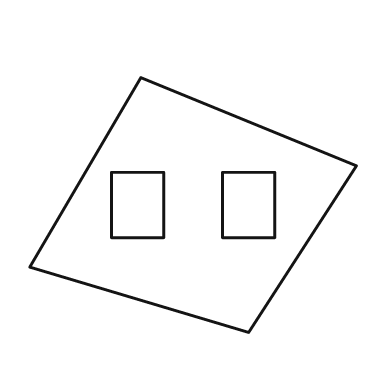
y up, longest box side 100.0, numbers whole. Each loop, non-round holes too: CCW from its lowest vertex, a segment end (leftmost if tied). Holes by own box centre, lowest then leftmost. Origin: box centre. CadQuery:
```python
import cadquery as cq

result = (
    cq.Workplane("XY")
    .moveTo(17.0, -39.0)
    .lineTo(50.0, 12.0)
    .lineTo(-16.0, 39.0)
    .lineTo(-50.0, -19.0)
    .close()
    .moveTo(-25.0, -10.0)
    .lineTo(-9.0, -10.0)
    .lineTo(-9.0, 10.0)
    .lineTo(-25.0, 10.0)
    .close()
    .moveTo(9.0, -10.0)
    .lineTo(25.0, -10.0)
    .lineTo(25.0, 10.0)
    .lineTo(9.0, 10.0)
    .close()
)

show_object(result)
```